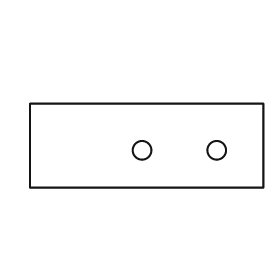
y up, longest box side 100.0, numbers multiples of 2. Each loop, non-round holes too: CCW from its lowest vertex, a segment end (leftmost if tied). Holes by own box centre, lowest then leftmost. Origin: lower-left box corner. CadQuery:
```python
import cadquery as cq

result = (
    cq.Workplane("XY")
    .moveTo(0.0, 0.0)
    .lineTo(100.0, 0.0)
    .lineTo(100.0, 36.0)
    .lineTo(0.0, 36.0)
    .close()
    .moveTo(48.0, 16.0)
    .circle(4.0)
    .moveTo(80.0, 16.0)
    .circle(4.0)
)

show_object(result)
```